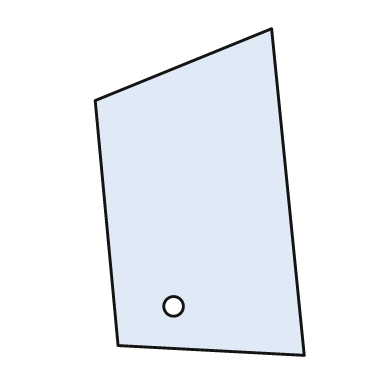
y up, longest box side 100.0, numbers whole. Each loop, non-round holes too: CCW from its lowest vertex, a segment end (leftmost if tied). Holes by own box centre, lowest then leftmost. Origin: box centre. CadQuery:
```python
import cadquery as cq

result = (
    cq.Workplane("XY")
    .moveTo(32.0, -50.0)
    .lineTo(22.0, 50.0)
    .lineTo(-32.0, 28.0)
    .lineTo(-25.0, -47.0)
    .close()
    .moveTo(-8.0, -35.0)
    .circle(3.0)
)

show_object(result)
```